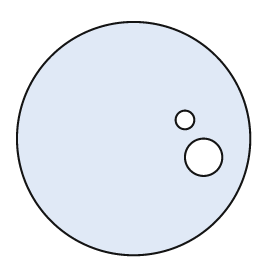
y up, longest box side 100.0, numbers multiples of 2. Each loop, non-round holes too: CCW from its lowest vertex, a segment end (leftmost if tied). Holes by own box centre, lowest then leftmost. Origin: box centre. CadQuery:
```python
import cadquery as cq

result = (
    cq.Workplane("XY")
    .moveTo(0.0, 0.0)
    .circle(50.0)
    .moveTo(30.0, -8.0)
    .circle(8.0)
    .moveTo(22.0, 8.0)
    .circle(4.0)
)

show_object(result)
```